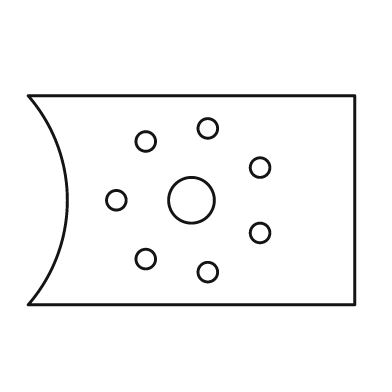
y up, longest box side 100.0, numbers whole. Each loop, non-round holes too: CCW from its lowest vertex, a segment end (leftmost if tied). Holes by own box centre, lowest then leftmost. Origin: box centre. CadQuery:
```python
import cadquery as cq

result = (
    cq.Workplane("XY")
    .moveTo(-50.0, -32.0)
    .lineTo(50.0, -32.0)
    .lineTo(50.0, 32.0)
    .lineTo(-50.0, 32.0)
    .threePointArc((-38.0, 0.0), (-50.0, -32.0))
    .close()
    .moveTo(5.0, -22.0)
    .circle(3.0)
    .moveTo(-14.0, -18.0)
    .circle(3.0)
    .moveTo(21.0, -10.0)
    .circle(3.0)
    .moveTo(-23.0, 0.0)
    .circle(3.0)
    .moveTo(0.0, 0.0)
    .circle(7.0)
    .moveTo(21.0, 10.0)
    .circle(3.0)
    .moveTo(-14.0, 18.0)
    .circle(3.0)
    .moveTo(5.0, 22.0)
    .circle(3.0)
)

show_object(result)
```